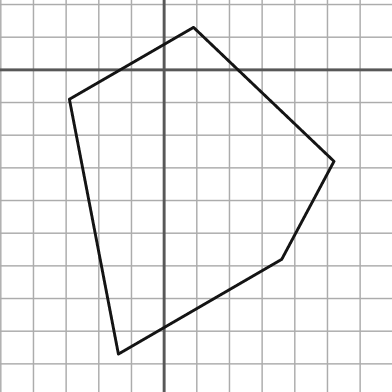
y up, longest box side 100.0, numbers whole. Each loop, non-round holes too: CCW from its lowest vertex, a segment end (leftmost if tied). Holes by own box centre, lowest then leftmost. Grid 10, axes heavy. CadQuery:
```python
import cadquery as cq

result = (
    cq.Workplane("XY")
    .moveTo(-14.0, -87.0)
    .lineTo(36.0, -58.0)
    .lineTo(52.0, -28.0)
    .lineTo(9.0, 13.0)
    .lineTo(-29.0, -9.0)
    .close()
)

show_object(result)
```